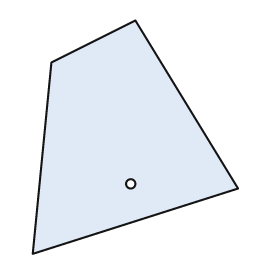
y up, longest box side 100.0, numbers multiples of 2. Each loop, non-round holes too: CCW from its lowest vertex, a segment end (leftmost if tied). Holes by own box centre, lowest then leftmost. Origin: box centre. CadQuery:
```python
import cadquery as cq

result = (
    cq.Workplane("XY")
    .moveTo(-44.0, -50.0)
    .lineTo(44.0, -22.0)
    .lineTo(0.0, 50.0)
    .lineTo(-36.0, 32.0)
    .close()
    .moveTo(-2.0, -20.0)
    .circle(2.0)
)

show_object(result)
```